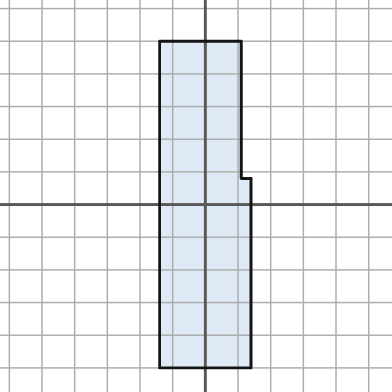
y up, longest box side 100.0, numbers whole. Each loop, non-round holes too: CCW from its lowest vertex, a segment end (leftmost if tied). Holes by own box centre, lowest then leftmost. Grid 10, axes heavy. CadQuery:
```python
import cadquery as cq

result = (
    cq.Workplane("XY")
    .moveTo(-14.0, -50.0)
    .lineTo(14.0, -50.0)
    .lineTo(14.0, 8.0)
    .lineTo(11.0, 8.0)
    .lineTo(11.0, 50.0)
    .lineTo(-14.0, 50.0)
    .close()
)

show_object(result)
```